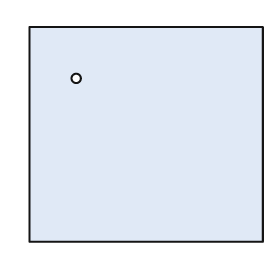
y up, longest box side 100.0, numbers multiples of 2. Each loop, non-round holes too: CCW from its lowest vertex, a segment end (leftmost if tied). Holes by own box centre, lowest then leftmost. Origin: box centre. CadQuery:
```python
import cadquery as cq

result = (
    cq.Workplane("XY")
    .moveTo(-50.0, -46.0)
    .lineTo(50.0, -46.0)
    .lineTo(50.0, 46.0)
    .lineTo(-50.0, 46.0)
    .close()
    .moveTo(-30.0, 24.0)
    .circle(2.0)
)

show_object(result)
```